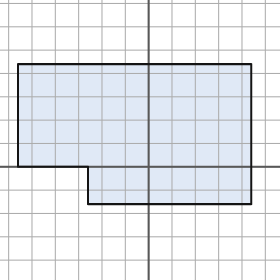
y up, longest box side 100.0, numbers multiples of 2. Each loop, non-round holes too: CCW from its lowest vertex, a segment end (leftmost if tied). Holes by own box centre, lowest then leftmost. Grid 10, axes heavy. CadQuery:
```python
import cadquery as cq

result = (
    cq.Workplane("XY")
    .moveTo(-26.0, -16.0)
    .lineTo(44.0, -16.0)
    .lineTo(44.0, 44.0)
    .lineTo(-56.0, 44.0)
    .lineTo(-56.0, 0.0)
    .lineTo(-26.0, 0.0)
    .close()
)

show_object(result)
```